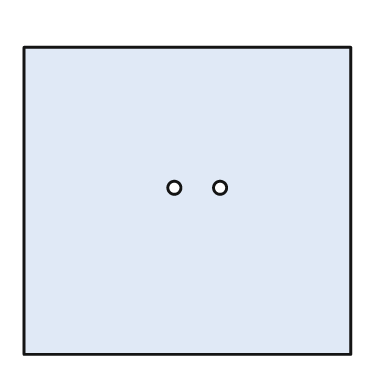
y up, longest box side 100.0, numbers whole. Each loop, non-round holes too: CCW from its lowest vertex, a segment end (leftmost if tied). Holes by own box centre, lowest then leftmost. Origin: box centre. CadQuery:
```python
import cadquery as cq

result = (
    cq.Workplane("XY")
    .moveTo(-50.0, -47.0)
    .lineTo(50.0, -47.0)
    .lineTo(50.0, 47.0)
    .lineTo(-50.0, 47.0)
    .close()
    .moveTo(-4.0, 4.0)
    .circle(2.0)
    .moveTo(10.0, 4.0)
    .circle(2.0)
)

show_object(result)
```